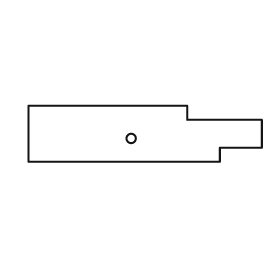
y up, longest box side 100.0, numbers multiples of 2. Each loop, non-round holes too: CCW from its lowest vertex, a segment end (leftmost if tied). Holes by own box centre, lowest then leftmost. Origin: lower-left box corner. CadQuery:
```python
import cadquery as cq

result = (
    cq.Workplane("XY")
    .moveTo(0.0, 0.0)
    .lineTo(82.0, 0.0)
    .lineTo(82.0, 6.0)
    .lineTo(100.0, 6.0)
    .lineTo(100.0, 18.0)
    .lineTo(68.0, 18.0)
    .lineTo(68.0, 24.0)
    .lineTo(0.0, 24.0)
    .close()
    .moveTo(44.0, 10.0)
    .circle(2.0)
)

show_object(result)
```